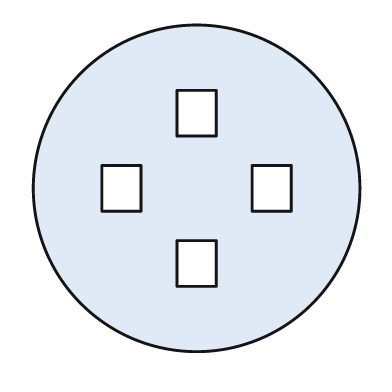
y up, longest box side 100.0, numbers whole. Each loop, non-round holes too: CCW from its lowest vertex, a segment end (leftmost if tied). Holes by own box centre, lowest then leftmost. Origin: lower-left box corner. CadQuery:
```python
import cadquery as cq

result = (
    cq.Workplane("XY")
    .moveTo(50.0, 50.0)
    .circle(50.0)
    .moveTo(44.0, 20.0)
    .lineTo(56.0, 20.0)
    .lineTo(56.0, 34.0)
    .lineTo(44.0, 34.0)
    .close()
    .moveTo(21.0, 43.0)
    .lineTo(33.0, 43.0)
    .lineTo(33.0, 57.0)
    .lineTo(21.0, 57.0)
    .close()
    .moveTo(67.0, 43.0)
    .lineTo(79.0, 43.0)
    .lineTo(79.0, 57.0)
    .lineTo(67.0, 57.0)
    .close()
    .moveTo(44.0, 66.0)
    .lineTo(56.0, 66.0)
    .lineTo(56.0, 80.0)
    .lineTo(44.0, 80.0)
    .close()
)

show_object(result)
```